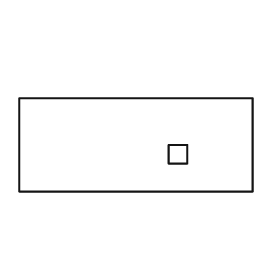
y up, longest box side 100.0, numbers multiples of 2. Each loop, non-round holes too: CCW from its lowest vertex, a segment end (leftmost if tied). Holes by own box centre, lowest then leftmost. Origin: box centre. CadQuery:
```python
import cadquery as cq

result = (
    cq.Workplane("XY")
    .moveTo(-50.0, -20.0)
    .lineTo(50.0, -20.0)
    .lineTo(50.0, 20.0)
    .lineTo(-50.0, 20.0)
    .close()
    .moveTo(14.0, -8.0)
    .lineTo(22.0, -8.0)
    .lineTo(22.0, 0.0)
    .lineTo(14.0, 0.0)
    .close()
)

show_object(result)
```